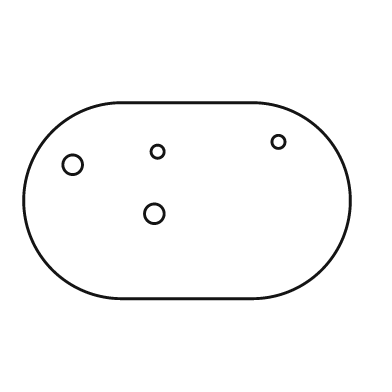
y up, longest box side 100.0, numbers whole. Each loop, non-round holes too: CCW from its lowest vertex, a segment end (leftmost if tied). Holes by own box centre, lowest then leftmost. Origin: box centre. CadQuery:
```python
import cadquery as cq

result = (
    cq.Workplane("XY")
    .moveTo(-20.0, -30.0)
    .lineTo(20.0, -30.0)
    .threePointArc((50.0, 0.0), (20.0, 30.0))
    .lineTo(-20.0, 30.0)
    .threePointArc((-50.0, 0.0), (-20.0, -30.0))
    .close()
    .moveTo(-10.0, -4.0)
    .circle(3.0)
    .moveTo(-35.0, 11.0)
    .circle(3.0)
    .moveTo(-9.0, 15.0)
    .circle(2.0)
    .moveTo(28.0, 18.0)
    .circle(2.0)
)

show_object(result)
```